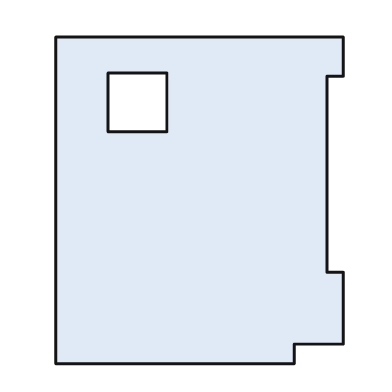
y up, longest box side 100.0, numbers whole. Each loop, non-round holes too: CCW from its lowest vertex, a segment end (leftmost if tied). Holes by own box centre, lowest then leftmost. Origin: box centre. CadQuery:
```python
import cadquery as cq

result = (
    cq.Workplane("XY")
    .moveTo(-44.0, -50.0)
    .lineTo(29.0, -50.0)
    .lineTo(29.0, -44.0)
    .lineTo(44.0, -44.0)
    .lineTo(44.0, -22.0)
    .lineTo(39.0, -22.0)
    .lineTo(39.0, 38.0)
    .lineTo(44.0, 38.0)
    .lineTo(44.0, 50.0)
    .lineTo(-44.0, 50.0)
    .close()
    .moveTo(-28.0, 21.0)
    .lineTo(-10.0, 21.0)
    .lineTo(-10.0, 39.0)
    .lineTo(-28.0, 39.0)
    .close()
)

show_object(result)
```